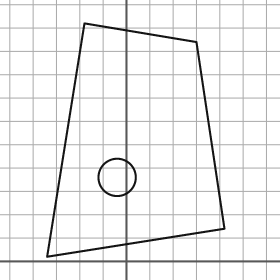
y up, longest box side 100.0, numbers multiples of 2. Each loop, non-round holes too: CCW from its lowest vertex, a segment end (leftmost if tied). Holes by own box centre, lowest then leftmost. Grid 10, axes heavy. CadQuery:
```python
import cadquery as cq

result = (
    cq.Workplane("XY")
    .moveTo(-34.0, 2.0)
    .lineTo(42.0, 14.0)
    .lineTo(30.0, 94.0)
    .lineTo(-18.0, 102.0)
    .close()
    .moveTo(-4.0, 36.0)
    .circle(8.0)
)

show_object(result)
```